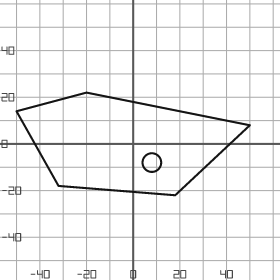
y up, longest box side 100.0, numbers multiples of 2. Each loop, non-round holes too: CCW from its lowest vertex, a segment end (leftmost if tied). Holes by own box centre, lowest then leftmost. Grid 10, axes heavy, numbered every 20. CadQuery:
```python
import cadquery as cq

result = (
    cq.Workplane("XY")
    .moveTo(18.0, -22.0)
    .lineTo(50.0, 8.0)
    .lineTo(-20.0, 22.0)
    .lineTo(-50.0, 14.0)
    .lineTo(-32.0, -18.0)
    .close()
    .moveTo(8.0, -8.0)
    .circle(4.0)
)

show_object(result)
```